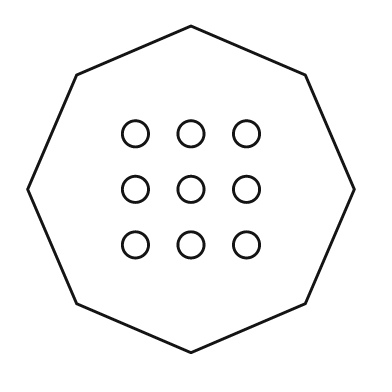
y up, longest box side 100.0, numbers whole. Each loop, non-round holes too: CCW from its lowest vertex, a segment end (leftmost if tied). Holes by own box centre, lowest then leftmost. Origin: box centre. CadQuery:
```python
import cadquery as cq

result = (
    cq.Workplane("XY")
    .moveTo(0.0, -50.0)
    .lineTo(35.0, -35.0)
    .lineTo(50.0, 0.0)
    .lineTo(35.0, 35.0)
    .lineTo(0.0, 50.0)
    .lineTo(-35.0, 35.0)
    .lineTo(-50.0, 0.0)
    .lineTo(-35.0, -35.0)
    .close()
    .moveTo(-17.0, -17.0)
    .circle(4.0)
    .moveTo(0.0, -17.0)
    .circle(4.0)
    .moveTo(17.0, -17.0)
    .circle(4.0)
    .moveTo(-17.0, 0.0)
    .circle(4.0)
    .moveTo(0.0, 0.0)
    .circle(4.0)
    .moveTo(17.0, 0.0)
    .circle(4.0)
    .moveTo(-17.0, 17.0)
    .circle(4.0)
    .moveTo(0.0, 17.0)
    .circle(4.0)
    .moveTo(17.0, 17.0)
    .circle(4.0)
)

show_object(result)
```